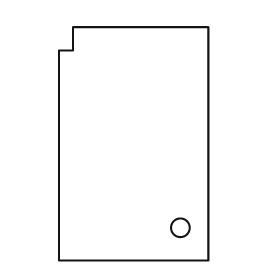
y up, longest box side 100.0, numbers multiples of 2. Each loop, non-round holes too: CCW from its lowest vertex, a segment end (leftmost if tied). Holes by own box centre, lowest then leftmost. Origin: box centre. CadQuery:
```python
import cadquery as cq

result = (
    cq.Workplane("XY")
    .moveTo(-32.0, -50.0)
    .lineTo(32.0, -50.0)
    .lineTo(32.0, 50.0)
    .lineTo(-26.0, 50.0)
    .lineTo(-26.0, 40.0)
    .lineTo(-32.0, 40.0)
    .close()
    .moveTo(20.0, -36.0)
    .circle(4.0)
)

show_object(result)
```